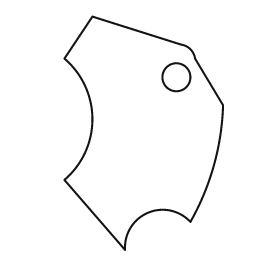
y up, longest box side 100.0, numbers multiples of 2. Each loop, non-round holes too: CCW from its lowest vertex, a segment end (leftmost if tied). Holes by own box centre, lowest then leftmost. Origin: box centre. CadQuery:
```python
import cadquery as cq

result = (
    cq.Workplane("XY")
    .moveTo(-8.0, -50.0)
    .threePointArc((2.0, -34.0), (20.0, -38.0))
    .threePointArc((30.0, -14.0), (34.0, 12.0))
    .lineTo(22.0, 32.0)
    .threePointArc((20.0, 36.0), (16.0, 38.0))
    .lineTo(-22.0, 50.0)
    .lineTo(-34.0, 32.0)
    .threePointArc((-22.0, 6.0), (-34.0, -20.0))
    .close()
    .moveTo(14.0, 24.0)
    .circle(6.0)
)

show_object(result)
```